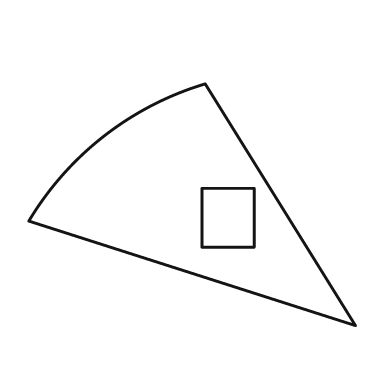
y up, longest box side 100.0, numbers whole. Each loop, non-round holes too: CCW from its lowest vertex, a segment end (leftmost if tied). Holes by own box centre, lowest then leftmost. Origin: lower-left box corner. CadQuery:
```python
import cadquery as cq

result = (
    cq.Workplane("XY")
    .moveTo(100.0, 0.0)
    .lineTo(54.0, 74.0)
    .threePointArc((23.0, 58.0), (0.0, 32.0))
    .close()
    .moveTo(53.0, 24.0)
    .lineTo(69.0, 24.0)
    .lineTo(69.0, 42.0)
    .lineTo(53.0, 42.0)
    .close()
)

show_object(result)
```